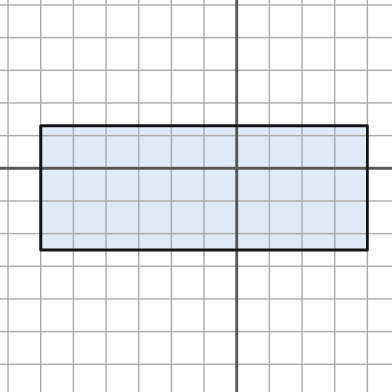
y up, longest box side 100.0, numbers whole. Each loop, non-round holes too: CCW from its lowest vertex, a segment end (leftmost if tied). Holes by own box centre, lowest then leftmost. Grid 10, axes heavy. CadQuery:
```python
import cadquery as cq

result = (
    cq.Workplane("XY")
    .moveTo(-60.0, -25.0)
    .lineTo(40.0, -25.0)
    .lineTo(40.0, 13.0)
    .lineTo(-60.0, 13.0)
    .close()
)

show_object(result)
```